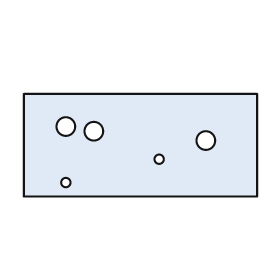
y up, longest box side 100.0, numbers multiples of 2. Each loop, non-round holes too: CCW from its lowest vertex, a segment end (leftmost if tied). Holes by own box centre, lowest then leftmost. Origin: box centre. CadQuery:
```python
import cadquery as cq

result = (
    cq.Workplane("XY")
    .moveTo(-50.0, -22.0)
    .lineTo(50.0, -22.0)
    .lineTo(50.0, 22.0)
    .lineTo(-50.0, 22.0)
    .close()
    .moveTo(-32.0, -16.0)
    .circle(2.0)
    .moveTo(8.0, -6.0)
    .circle(2.0)
    .moveTo(28.0, 2.0)
    .circle(4.0)
    .moveTo(-20.0, 6.0)
    .circle(4.0)
    .moveTo(-32.0, 8.0)
    .circle(4.0)
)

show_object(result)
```